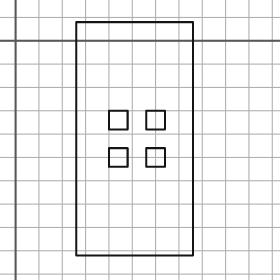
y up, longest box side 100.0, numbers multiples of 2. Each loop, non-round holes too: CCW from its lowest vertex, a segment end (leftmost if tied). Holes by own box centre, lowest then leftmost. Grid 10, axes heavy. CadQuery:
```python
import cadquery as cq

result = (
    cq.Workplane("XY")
    .moveTo(26.0, -92.0)
    .lineTo(76.0, -92.0)
    .lineTo(76.0, 8.0)
    .lineTo(26.0, 8.0)
    .close()
    .moveTo(40.0, -54.0)
    .lineTo(48.0, -54.0)
    .lineTo(48.0, -46.0)
    .lineTo(40.0, -46.0)
    .close()
    .moveTo(56.0, -54.0)
    .lineTo(64.0, -54.0)
    .lineTo(64.0, -46.0)
    .lineTo(56.0, -46.0)
    .close()
    .moveTo(40.0, -38.0)
    .lineTo(48.0, -38.0)
    .lineTo(48.0, -30.0)
    .lineTo(40.0, -30.0)
    .close()
    .moveTo(56.0, -38.0)
    .lineTo(64.0, -38.0)
    .lineTo(64.0, -30.0)
    .lineTo(56.0, -30.0)
    .close()
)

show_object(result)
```